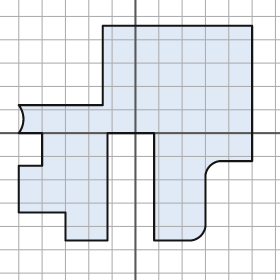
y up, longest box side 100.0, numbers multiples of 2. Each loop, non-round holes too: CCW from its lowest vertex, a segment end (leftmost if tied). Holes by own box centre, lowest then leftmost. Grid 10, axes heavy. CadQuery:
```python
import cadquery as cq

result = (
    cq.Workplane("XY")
    .moveTo(-30.0, -46.0)
    .lineTo(-12.0, -46.0)
    .lineTo(-12.0, 0.0)
    .lineTo(8.0, 0.0)
    .lineTo(8.0, -46.0)
    .lineTo(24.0, -46.0)
    .threePointArc((28.0, -44.0), (30.0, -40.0))
    .lineTo(30.0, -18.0)
    .threePointArc((32.0, -14.0), (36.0, -12.0))
    .lineTo(50.0, -12.0)
    .lineTo(50.0, 46.0)
    .lineTo(-14.0, 46.0)
    .lineTo(-14.0, 12.0)
    .lineTo(-50.0, 12.0)
    .threePointArc((-48.0, 6.0), (-50.0, 0.0))
    .lineTo(-40.0, 0.0)
    .lineTo(-40.0, -14.0)
    .lineTo(-50.0, -14.0)
    .lineTo(-50.0, -34.0)
    .lineTo(-30.0, -34.0)
    .close()
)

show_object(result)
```